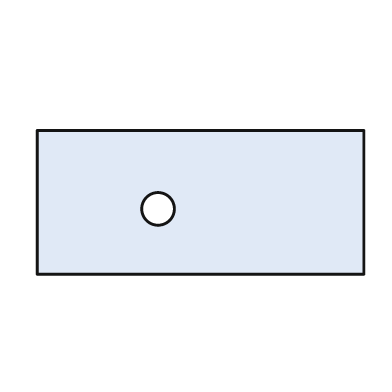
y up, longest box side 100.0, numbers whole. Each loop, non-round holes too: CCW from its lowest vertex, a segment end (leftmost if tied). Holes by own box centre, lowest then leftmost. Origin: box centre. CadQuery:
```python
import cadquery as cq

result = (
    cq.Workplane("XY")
    .moveTo(-50.0, -22.0)
    .lineTo(50.0, -22.0)
    .lineTo(50.0, 22.0)
    .lineTo(-50.0, 22.0)
    .close()
    .moveTo(-13.0, -2.0)
    .circle(5.0)
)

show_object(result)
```